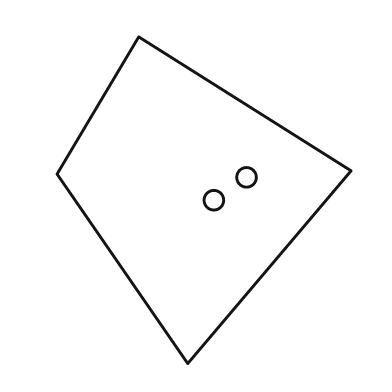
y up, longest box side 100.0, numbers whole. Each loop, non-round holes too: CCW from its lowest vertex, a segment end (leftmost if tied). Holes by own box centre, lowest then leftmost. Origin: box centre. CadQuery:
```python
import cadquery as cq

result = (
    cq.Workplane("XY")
    .moveTo(-5.0, -50.0)
    .lineTo(45.0, 9.0)
    .lineTo(-20.0, 50.0)
    .lineTo(-45.0, 8.0)
    .close()
    .moveTo(3.0, 0.0)
    .circle(3.0)
    .moveTo(13.0, 7.0)
    .circle(3.0)
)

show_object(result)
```